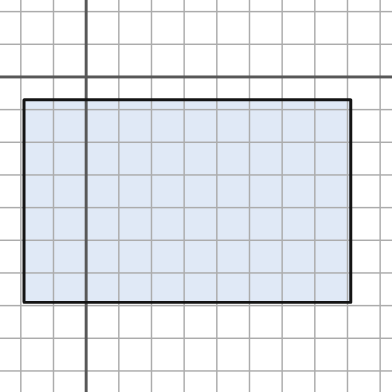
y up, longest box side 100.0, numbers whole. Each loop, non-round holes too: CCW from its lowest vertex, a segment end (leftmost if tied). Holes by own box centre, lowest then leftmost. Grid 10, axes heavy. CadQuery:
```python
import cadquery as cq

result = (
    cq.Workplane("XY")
    .moveTo(-19.0, -69.0)
    .lineTo(81.0, -69.0)
    .lineTo(81.0, -7.0)
    .lineTo(-19.0, -7.0)
    .close()
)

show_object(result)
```